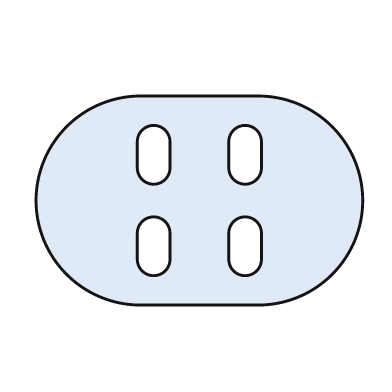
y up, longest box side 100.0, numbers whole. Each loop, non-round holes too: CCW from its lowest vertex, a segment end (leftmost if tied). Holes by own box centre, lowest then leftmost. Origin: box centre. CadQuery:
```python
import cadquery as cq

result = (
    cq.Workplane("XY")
    .moveTo(-18.0, -32.0)
    .lineTo(18.0, -32.0)
    .threePointArc((50.0, 0.0), (18.0, 32.0))
    .lineTo(-18.0, 32.0)
    .threePointArc((-50.0, 0.0), (-18.0, -32.0))
    .close()
    .moveTo(-19.0, -18.0)
    .threePointArc((-14.0, -23.0), (-9.0, -18.0))
    .lineTo(-9.0, -10.0)
    .threePointArc((-14.0, -5.0), (-19.0, -10.0))
    .close()
    .moveTo(9.0, -18.0)
    .threePointArc((14.0, -23.0), (19.0, -18.0))
    .lineTo(19.0, -10.0)
    .threePointArc((14.0, -5.0), (9.0, -10.0))
    .close()
    .moveTo(-19.0, 10.0)
    .threePointArc((-14.0, 5.0), (-9.0, 10.0))
    .lineTo(-9.0, 18.0)
    .threePointArc((-14.0, 23.0), (-19.0, 18.0))
    .close()
    .moveTo(9.0, 10.0)
    .threePointArc((14.0, 5.0), (19.0, 10.0))
    .lineTo(19.0, 18.0)
    .threePointArc((14.0, 23.0), (9.0, 18.0))
    .close()
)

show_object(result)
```